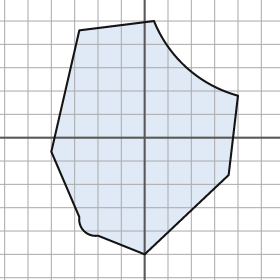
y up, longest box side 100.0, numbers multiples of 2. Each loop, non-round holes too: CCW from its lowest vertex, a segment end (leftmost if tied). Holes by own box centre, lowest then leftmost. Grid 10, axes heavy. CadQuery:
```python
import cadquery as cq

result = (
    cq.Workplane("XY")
    .moveTo(0.0, -50.0)
    .lineTo(36.0, -16.0)
    .lineTo(40.0, 18.0)
    .threePointArc((18.0, 30.0), (4.0, 50.0))
    .lineTo(-28.0, 46.0)
    .lineTo(-40.0, -6.0)
    .lineTo(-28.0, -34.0)
    .threePointArc((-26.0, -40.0), (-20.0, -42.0))
    .close()
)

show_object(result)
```